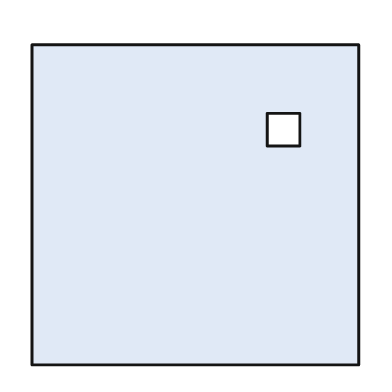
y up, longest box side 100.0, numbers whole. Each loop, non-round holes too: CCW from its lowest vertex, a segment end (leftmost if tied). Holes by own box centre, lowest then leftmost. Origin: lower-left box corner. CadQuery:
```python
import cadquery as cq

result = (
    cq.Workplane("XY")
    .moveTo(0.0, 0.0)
    .lineTo(100.0, 0.0)
    .lineTo(100.0, 98.0)
    .lineTo(0.0, 98.0)
    .close()
    .moveTo(72.0, 67.0)
    .lineTo(82.0, 67.0)
    .lineTo(82.0, 77.0)
    .lineTo(72.0, 77.0)
    .close()
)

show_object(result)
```